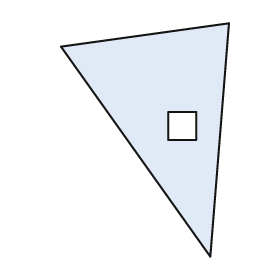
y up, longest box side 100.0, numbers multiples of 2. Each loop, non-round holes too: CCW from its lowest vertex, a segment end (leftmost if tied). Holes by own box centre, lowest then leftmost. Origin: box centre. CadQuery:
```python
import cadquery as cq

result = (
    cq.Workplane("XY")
    .moveTo(28.0, -50.0)
    .lineTo(36.0, 50.0)
    .lineTo(-36.0, 40.0)
    .close()
    .moveTo(10.0, 0.0)
    .lineTo(22.0, 0.0)
    .lineTo(22.0, 12.0)
    .lineTo(10.0, 12.0)
    .close()
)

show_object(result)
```